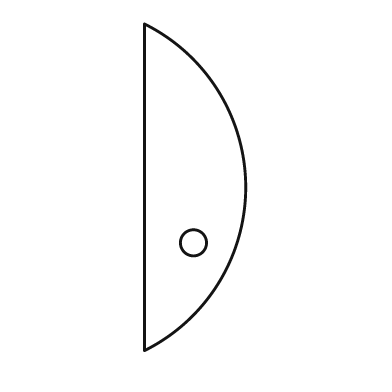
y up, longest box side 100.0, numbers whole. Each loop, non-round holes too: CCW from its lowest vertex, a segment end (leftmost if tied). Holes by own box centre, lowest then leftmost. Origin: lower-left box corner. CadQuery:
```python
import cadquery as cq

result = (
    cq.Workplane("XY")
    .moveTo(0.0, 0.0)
    .threePointArc((31.0, 50.0), (0.0, 100.0))
    .close()
    .moveTo(15.0, 33.0)
    .circle(4.0)
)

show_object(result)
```